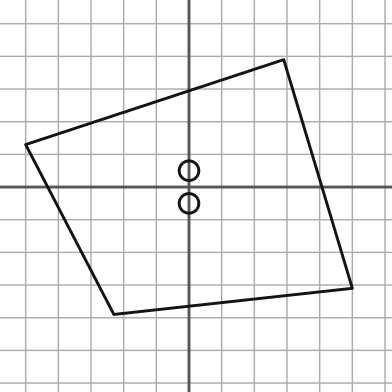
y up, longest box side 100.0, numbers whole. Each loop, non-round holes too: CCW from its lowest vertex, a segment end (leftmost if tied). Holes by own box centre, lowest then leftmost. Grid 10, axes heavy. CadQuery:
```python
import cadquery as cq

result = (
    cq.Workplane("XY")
    .moveTo(-23.0, -39.0)
    .lineTo(50.0, -31.0)
    .lineTo(29.0, 39.0)
    .lineTo(-50.0, 13.0)
    .close()
    .moveTo(0.0, -5.0)
    .circle(3.0)
    .moveTo(0.0, 5.0)
    .circle(3.0)
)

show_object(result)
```